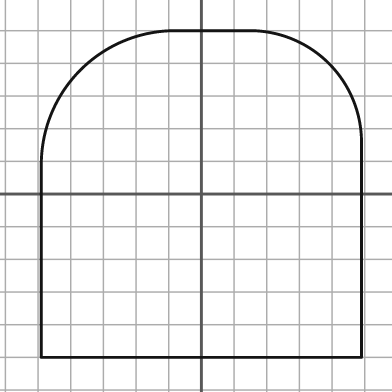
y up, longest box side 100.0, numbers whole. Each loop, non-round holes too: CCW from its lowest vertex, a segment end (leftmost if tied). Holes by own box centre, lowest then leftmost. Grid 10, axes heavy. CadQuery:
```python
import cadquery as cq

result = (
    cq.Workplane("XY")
    .moveTo(-49.0, -50.0)
    .lineTo(49.0, -50.0)
    .lineTo(49.0, 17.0)
    .threePointArc((39.0, 40.0), (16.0, 50.0))
    .lineTo(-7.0, 50.0)
    .threePointArc((-37.0, 38.0), (-49.0, 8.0))
    .close()
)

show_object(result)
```